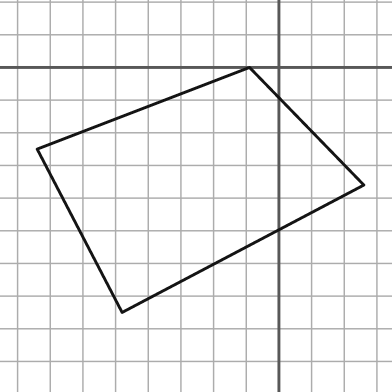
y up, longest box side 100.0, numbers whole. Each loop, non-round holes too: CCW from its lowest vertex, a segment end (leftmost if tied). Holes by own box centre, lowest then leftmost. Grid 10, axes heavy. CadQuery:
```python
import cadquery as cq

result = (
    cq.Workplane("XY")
    .moveTo(-48.0, -75.0)
    .lineTo(26.0, -36.0)
    .lineTo(-9.0, 0.0)
    .lineTo(-74.0, -25.0)
    .close()
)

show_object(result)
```